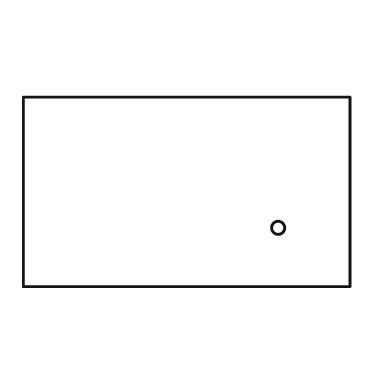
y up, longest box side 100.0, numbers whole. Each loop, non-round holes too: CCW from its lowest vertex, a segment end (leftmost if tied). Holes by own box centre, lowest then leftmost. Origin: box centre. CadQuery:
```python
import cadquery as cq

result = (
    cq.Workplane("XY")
    .moveTo(-50.0, -29.0)
    .lineTo(50.0, -29.0)
    .lineTo(50.0, 29.0)
    .lineTo(-50.0, 29.0)
    .close()
    .moveTo(28.0, -11.0)
    .circle(2.0)
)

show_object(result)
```